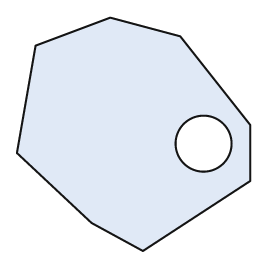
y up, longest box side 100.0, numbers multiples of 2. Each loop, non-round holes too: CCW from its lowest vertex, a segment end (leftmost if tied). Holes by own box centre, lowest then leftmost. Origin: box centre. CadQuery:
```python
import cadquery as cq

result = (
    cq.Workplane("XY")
    .moveTo(4.0, -50.0)
    .lineTo(50.0, -20.0)
    .lineTo(50.0, 4.0)
    .lineTo(20.0, 42.0)
    .lineTo(-10.0, 50.0)
    .lineTo(-42.0, 38.0)
    .lineTo(-50.0, -8.0)
    .lineTo(-18.0, -38.0)
    .close()
    .moveTo(30.0, -4.0)
    .circle(12.0)
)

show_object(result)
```